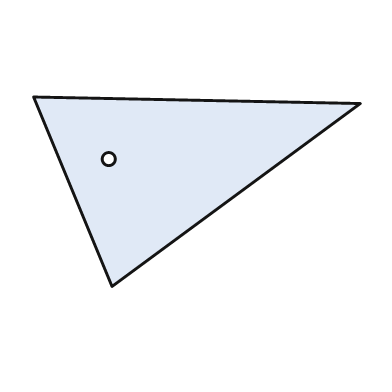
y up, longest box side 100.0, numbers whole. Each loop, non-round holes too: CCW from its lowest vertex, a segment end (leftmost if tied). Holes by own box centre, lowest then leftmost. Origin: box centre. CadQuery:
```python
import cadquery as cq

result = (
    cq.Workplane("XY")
    .moveTo(-26.0, -29.0)
    .lineTo(50.0, 27.0)
    .lineTo(-50.0, 29.0)
    .close()
    .moveTo(-27.0, 10.0)
    .circle(2.0)
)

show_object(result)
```